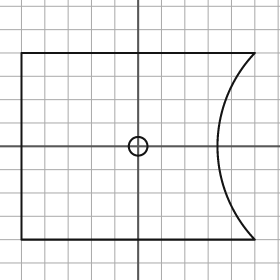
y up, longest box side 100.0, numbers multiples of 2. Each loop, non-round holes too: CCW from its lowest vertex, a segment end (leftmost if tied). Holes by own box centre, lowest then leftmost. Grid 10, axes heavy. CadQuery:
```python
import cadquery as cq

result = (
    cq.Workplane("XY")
    .moveTo(-50.0, -40.0)
    .lineTo(50.0, -40.0)
    .threePointArc((34.0, 0.0), (50.0, 40.0))
    .lineTo(-50.0, 40.0)
    .close()
    .moveTo(0.0, 0.0)
    .circle(4.0)
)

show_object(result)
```